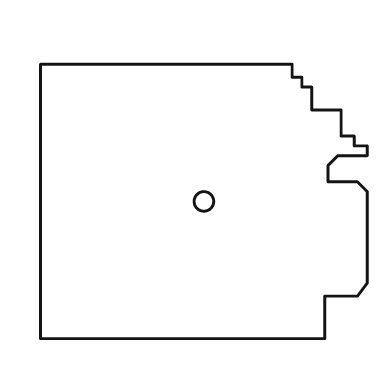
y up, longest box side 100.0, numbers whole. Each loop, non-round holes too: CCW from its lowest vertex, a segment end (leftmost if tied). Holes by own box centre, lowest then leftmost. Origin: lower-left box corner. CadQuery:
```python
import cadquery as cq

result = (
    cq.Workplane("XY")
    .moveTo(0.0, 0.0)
    .lineTo(87.0, 0.0)
    .lineTo(87.0, 13.0)
    .lineTo(97.0, 13.0)
    .lineTo(100.0, 17.0)
    .lineTo(100.0, 45.0)
    .lineTo(97.0, 48.0)
    .lineTo(88.0, 48.0)
    .lineTo(88.0, 53.0)
    .lineTo(91.0, 56.0)
    .lineTo(100.0, 56.0)
    .lineTo(100.0, 59.0)
    .lineTo(96.0, 59.0)
    .lineTo(96.0, 62.0)
    .lineTo(92.0, 62.0)
    .lineTo(92.0, 70.0)
    .lineTo(83.0, 70.0)
    .lineTo(83.0, 77.0)
    .lineTo(80.0, 77.0)
    .lineTo(80.0, 80.0)
    .lineTo(77.0, 80.0)
    .lineTo(77.0, 84.0)
    .lineTo(0.0, 84.0)
    .close()
    .moveTo(50.0, 42.0)
    .circle(3.0)
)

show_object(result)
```